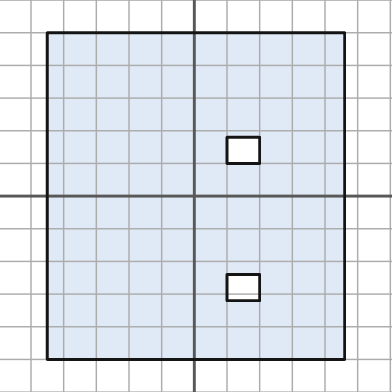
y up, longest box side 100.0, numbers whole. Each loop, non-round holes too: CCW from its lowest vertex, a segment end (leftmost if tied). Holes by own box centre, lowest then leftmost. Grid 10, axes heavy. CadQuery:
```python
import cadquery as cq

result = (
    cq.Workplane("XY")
    .moveTo(-45.0, -50.0)
    .lineTo(46.0, -50.0)
    .lineTo(46.0, 50.0)
    .lineTo(-45.0, 50.0)
    .close()
    .moveTo(10.0, -32.0)
    .lineTo(20.0, -32.0)
    .lineTo(20.0, -24.0)
    .lineTo(10.0, -24.0)
    .close()
    .moveTo(10.0, 10.0)
    .lineTo(20.0, 10.0)
    .lineTo(20.0, 18.0)
    .lineTo(10.0, 18.0)
    .close()
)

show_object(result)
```